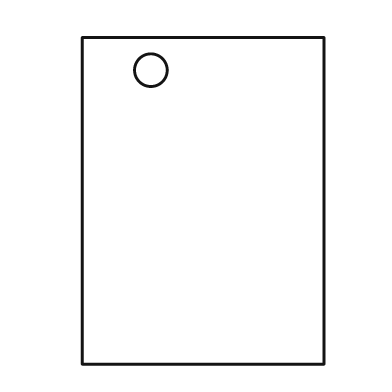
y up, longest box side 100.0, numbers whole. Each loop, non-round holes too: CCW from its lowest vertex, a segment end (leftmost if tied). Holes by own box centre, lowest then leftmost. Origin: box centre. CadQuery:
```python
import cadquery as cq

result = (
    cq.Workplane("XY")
    .moveTo(-37.0, -50.0)
    .lineTo(37.0, -50.0)
    .lineTo(37.0, 50.0)
    .lineTo(-37.0, 50.0)
    .close()
    .moveTo(-16.0, 40.0)
    .circle(5.0)
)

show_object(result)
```